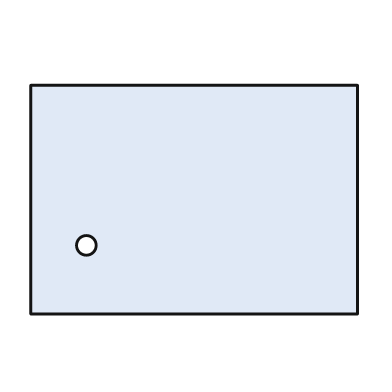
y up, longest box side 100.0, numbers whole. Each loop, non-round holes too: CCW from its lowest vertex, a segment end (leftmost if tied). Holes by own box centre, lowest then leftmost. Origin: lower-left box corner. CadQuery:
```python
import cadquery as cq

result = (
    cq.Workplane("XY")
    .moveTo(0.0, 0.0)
    .lineTo(100.0, 0.0)
    .lineTo(100.0, 70.0)
    .lineTo(0.0, 70.0)
    .close()
    .moveTo(17.0, 21.0)
    .circle(3.0)
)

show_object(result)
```